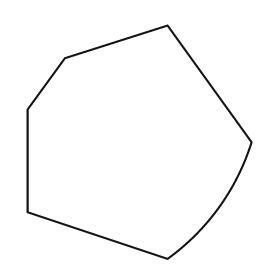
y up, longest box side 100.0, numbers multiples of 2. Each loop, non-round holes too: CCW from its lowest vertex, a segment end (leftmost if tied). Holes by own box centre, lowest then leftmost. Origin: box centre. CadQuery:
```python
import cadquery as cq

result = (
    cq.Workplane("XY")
    .moveTo(12.0, -50.0)
    .threePointArc((34.0, -28.0), (48.0, 0.0))
    .lineTo(12.0, 50.0)
    .lineTo(-32.0, 36.0)
    .lineTo(-48.0, 14.0)
    .lineTo(-48.0, -30.0)
    .close()
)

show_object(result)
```